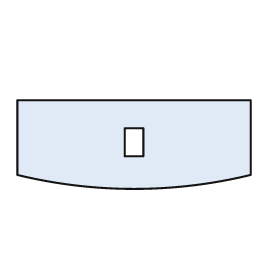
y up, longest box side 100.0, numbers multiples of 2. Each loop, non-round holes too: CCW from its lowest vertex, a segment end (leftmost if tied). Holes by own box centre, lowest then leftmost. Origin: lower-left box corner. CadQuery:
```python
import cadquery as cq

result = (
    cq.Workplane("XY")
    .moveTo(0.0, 6.0)
    .threePointArc((50.0, 0.0), (100.0, 6.0))
    .lineTo(100.0, 38.0)
    .lineTo(0.0, 38.0)
    .close()
    .moveTo(46.0, 14.0)
    .lineTo(54.0, 14.0)
    .lineTo(54.0, 26.0)
    .lineTo(46.0, 26.0)
    .close()
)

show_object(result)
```